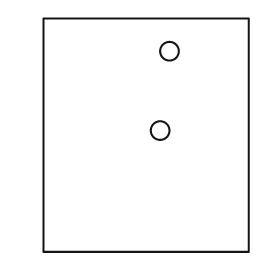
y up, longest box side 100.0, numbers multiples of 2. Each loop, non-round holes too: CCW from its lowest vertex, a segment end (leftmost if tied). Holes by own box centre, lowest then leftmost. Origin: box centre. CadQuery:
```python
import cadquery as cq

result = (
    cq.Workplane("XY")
    .moveTo(-44.0, -50.0)
    .lineTo(44.0, -50.0)
    .lineTo(44.0, 50.0)
    .lineTo(-44.0, 50.0)
    .close()
    .moveTo(6.0, 2.0)
    .circle(4.0)
    .moveTo(10.0, 36.0)
    .circle(4.0)
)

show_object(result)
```